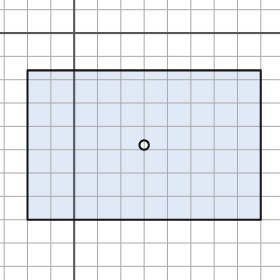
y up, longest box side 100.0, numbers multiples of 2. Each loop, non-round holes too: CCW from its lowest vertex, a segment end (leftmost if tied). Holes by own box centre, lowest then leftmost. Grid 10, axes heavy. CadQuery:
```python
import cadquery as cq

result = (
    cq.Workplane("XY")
    .moveTo(-20.0, -80.0)
    .lineTo(80.0, -80.0)
    .lineTo(80.0, -16.0)
    .lineTo(-20.0, -16.0)
    .close()
    .moveTo(30.0, -48.0)
    .circle(2.0)
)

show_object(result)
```